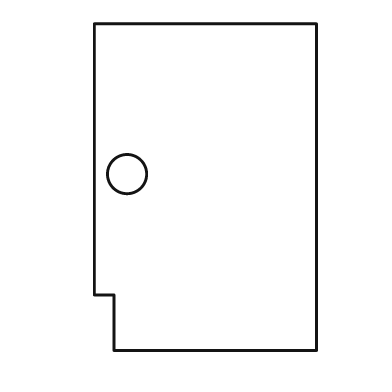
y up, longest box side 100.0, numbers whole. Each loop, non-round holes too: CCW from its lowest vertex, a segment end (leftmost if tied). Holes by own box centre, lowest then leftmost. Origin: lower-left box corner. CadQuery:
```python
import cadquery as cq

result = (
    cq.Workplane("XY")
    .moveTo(6.0, 0.0)
    .lineTo(68.0, 0.0)
    .lineTo(68.0, 100.0)
    .lineTo(0.0, 100.0)
    .lineTo(0.0, 17.0)
    .lineTo(6.0, 17.0)
    .close()
    .moveTo(10.0, 54.0)
    .circle(6.0)
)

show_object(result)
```